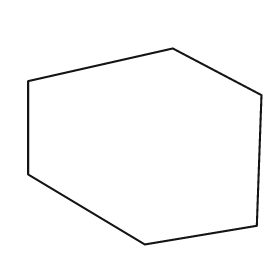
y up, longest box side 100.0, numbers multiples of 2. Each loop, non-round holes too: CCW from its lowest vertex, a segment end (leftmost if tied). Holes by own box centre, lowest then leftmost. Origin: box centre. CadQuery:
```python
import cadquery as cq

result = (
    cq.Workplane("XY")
    .moveTo(0.0, -42.0)
    .lineTo(48.0, -34.0)
    .lineTo(50.0, 22.0)
    .lineTo(12.0, 42.0)
    .lineTo(-50.0, 28.0)
    .lineTo(-50.0, -12.0)
    .close()
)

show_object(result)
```